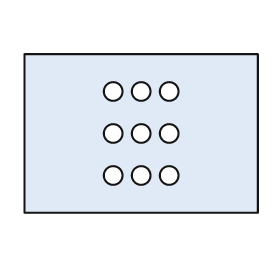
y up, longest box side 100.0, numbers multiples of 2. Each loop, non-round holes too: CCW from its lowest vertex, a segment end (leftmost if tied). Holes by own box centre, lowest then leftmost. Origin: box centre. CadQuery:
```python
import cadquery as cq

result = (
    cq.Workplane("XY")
    .moveTo(-50.0, -34.0)
    .lineTo(50.0, -34.0)
    .lineTo(50.0, 34.0)
    .lineTo(-50.0, 34.0)
    .close()
    .moveTo(-12.0, -18.0)
    .circle(4.0)
    .moveTo(0.0, -18.0)
    .circle(4.0)
    .moveTo(12.0, -18.0)
    .circle(4.0)
    .moveTo(-12.0, 0.0)
    .circle(4.0)
    .moveTo(0.0, 0.0)
    .circle(4.0)
    .moveTo(12.0, 0.0)
    .circle(4.0)
    .moveTo(-12.0, 18.0)
    .circle(4.0)
    .moveTo(0.0, 18.0)
    .circle(4.0)
    .moveTo(12.0, 18.0)
    .circle(4.0)
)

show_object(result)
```